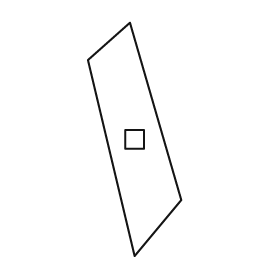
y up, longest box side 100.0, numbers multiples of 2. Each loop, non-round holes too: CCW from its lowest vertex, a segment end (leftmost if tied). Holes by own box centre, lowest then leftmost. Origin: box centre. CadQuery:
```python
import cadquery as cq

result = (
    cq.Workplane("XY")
    .moveTo(0.0, -50.0)
    .lineTo(20.0, -26.0)
    .lineTo(-2.0, 50.0)
    .lineTo(-20.0, 34.0)
    .close()
    .moveTo(-4.0, -4.0)
    .lineTo(4.0, -4.0)
    .lineTo(4.0, 4.0)
    .lineTo(-4.0, 4.0)
    .close()
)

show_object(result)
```